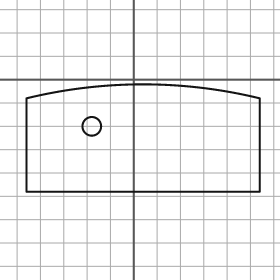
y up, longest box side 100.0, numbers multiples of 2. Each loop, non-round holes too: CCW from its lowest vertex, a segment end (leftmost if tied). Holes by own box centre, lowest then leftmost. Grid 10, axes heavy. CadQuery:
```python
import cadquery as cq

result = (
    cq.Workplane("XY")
    .moveTo(-46.0, -48.0)
    .lineTo(54.0, -48.0)
    .lineTo(54.0, -8.0)
    .threePointArc((4.0, -2.0), (-46.0, -8.0))
    .close()
    .moveTo(-18.0, -20.0)
    .circle(4.0)
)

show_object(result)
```